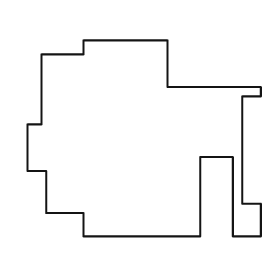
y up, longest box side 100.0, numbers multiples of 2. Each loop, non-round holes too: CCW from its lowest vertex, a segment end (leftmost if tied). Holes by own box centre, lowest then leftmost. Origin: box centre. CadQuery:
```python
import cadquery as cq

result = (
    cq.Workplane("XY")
    .moveTo(-26.0, -42.0)
    .lineTo(24.0, -42.0)
    .lineTo(24.0, -8.0)
    .lineTo(38.0, -8.0)
    .lineTo(38.0, -42.0)
    .lineTo(50.0, -42.0)
    .lineTo(50.0, -28.0)
    .lineTo(42.0, -28.0)
    .lineTo(42.0, 18.0)
    .lineTo(50.0, 18.0)
    .lineTo(50.0, 22.0)
    .lineTo(10.0, 22.0)
    .lineTo(10.0, 42.0)
    .lineTo(-26.0, 42.0)
    .lineTo(-26.0, 36.0)
    .lineTo(-44.0, 36.0)
    .lineTo(-44.0, 6.0)
    .lineTo(-50.0, 6.0)
    .lineTo(-50.0, -14.0)
    .lineTo(-42.0, -14.0)
    .lineTo(-42.0, -32.0)
    .lineTo(-26.0, -32.0)
    .close()
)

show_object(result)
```